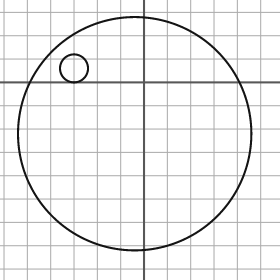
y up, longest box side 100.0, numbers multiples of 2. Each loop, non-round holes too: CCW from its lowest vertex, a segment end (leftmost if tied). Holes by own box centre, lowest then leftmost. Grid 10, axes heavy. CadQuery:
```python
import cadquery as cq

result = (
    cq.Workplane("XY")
    .moveTo(-4.0, -22.0)
    .circle(50.0)
    .moveTo(-30.0, 6.0)
    .circle(6.0)
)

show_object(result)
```